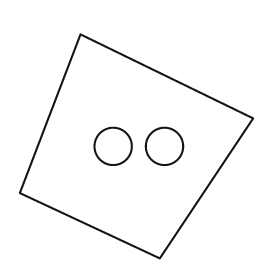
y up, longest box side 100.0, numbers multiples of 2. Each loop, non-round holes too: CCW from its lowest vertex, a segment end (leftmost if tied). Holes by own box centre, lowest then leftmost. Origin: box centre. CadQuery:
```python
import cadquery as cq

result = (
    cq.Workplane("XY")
    .moveTo(10.0, -48.0)
    .lineTo(50.0, 12.0)
    .lineTo(-24.0, 48.0)
    .lineTo(-50.0, -20.0)
    .close()
    .moveTo(-10.0, 0.0)
    .circle(8.0)
    .moveTo(12.0, 0.0)
    .circle(8.0)
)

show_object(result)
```